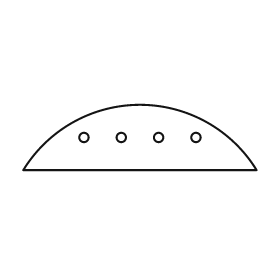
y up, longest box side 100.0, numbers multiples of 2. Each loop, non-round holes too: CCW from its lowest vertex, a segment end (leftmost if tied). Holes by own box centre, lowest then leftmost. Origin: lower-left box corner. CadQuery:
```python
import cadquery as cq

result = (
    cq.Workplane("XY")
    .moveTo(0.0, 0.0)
    .lineTo(100.0, 0.0)
    .threePointArc((50.0, 28.0), (0.0, 0.0))
    .close()
    .moveTo(26.0, 14.0)
    .circle(2.0)
    .moveTo(42.0, 14.0)
    .circle(2.0)
    .moveTo(58.0, 14.0)
    .circle(2.0)
    .moveTo(74.0, 14.0)
    .circle(2.0)
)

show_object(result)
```